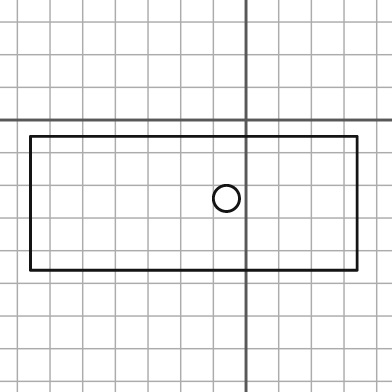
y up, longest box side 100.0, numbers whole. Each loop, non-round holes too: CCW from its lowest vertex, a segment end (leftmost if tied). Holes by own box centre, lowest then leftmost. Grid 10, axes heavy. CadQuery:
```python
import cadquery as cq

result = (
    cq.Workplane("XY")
    .moveTo(-66.0, -46.0)
    .lineTo(34.0, -46.0)
    .lineTo(34.0, -5.0)
    .lineTo(-66.0, -5.0)
    .close()
    .moveTo(-6.0, -24.0)
    .circle(4.0)
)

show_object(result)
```